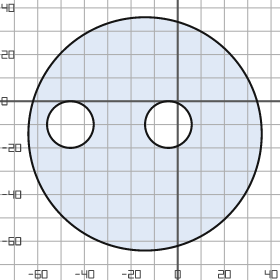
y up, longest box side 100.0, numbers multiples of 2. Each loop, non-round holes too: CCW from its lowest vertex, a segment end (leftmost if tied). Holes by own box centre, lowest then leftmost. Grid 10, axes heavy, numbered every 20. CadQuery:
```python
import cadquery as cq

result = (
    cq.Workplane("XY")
    .moveTo(-14.0, -14.0)
    .circle(50.0)
    .moveTo(-46.0, -10.0)
    .circle(10.0)
    .moveTo(-4.0, -10.0)
    .circle(10.0)
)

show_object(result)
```